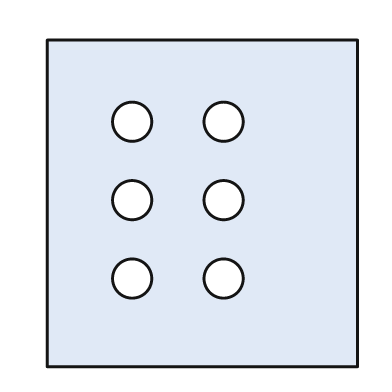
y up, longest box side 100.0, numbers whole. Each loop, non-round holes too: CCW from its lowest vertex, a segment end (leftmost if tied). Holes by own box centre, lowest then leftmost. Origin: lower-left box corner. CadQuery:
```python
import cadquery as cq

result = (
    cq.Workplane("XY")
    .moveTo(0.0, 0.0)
    .lineTo(95.0, 0.0)
    .lineTo(95.0, 100.0)
    .lineTo(0.0, 100.0)
    .close()
    .moveTo(26.0, 27.0)
    .circle(6.0)
    .moveTo(54.0, 27.0)
    .circle(6.0)
    .moveTo(26.0, 51.0)
    .circle(6.0)
    .moveTo(54.0, 51.0)
    .circle(6.0)
    .moveTo(26.0, 75.0)
    .circle(6.0)
    .moveTo(54.0, 75.0)
    .circle(6.0)
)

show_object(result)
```